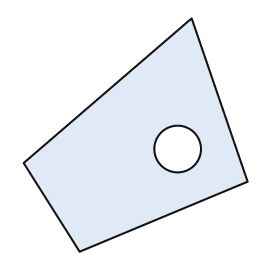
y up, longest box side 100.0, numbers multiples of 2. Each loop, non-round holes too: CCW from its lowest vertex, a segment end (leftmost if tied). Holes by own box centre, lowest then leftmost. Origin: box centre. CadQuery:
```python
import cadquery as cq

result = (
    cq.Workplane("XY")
    .moveTo(-24.0, -50.0)
    .lineTo(48.0, -20.0)
    .lineTo(24.0, 50.0)
    .lineTo(-48.0, -12.0)
    .close()
    .moveTo(18.0, -6.0)
    .circle(10.0)
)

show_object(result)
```